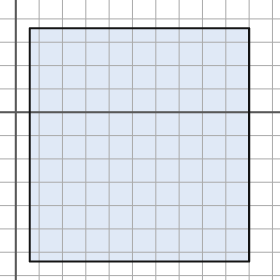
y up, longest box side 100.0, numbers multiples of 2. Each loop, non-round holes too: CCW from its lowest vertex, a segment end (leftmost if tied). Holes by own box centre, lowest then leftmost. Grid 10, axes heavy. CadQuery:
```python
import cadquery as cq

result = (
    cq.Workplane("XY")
    .moveTo(6.0, -64.0)
    .lineTo(100.0, -64.0)
    .lineTo(100.0, 36.0)
    .lineTo(6.0, 36.0)
    .close()
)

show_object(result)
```